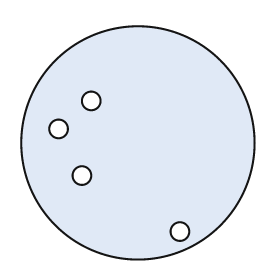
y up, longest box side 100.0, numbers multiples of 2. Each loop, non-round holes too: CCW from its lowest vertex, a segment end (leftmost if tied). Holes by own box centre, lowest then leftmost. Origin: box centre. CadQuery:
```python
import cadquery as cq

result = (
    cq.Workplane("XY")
    .moveTo(0.0, 0.0)
    .circle(50.0)
    .moveTo(18.0, -38.0)
    .circle(4.0)
    .moveTo(-24.0, -14.0)
    .circle(4.0)
    .moveTo(-34.0, 6.0)
    .circle(4.0)
    .moveTo(-20.0, 18.0)
    .circle(4.0)
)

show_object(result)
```